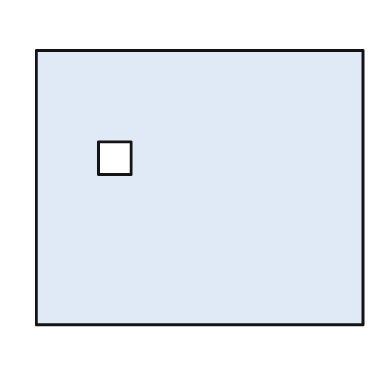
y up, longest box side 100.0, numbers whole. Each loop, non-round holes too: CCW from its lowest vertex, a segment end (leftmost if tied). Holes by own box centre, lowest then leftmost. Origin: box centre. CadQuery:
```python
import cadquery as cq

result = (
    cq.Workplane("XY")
    .moveTo(-50.0, -42.0)
    .lineTo(50.0, -42.0)
    .lineTo(50.0, 42.0)
    .lineTo(-50.0, 42.0)
    .close()
    .moveTo(-31.0, 4.0)
    .lineTo(-21.0, 4.0)
    .lineTo(-21.0, 14.0)
    .lineTo(-31.0, 14.0)
    .close()
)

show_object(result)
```